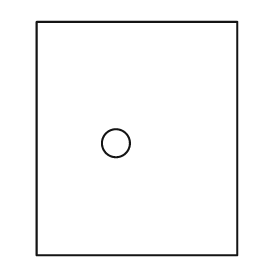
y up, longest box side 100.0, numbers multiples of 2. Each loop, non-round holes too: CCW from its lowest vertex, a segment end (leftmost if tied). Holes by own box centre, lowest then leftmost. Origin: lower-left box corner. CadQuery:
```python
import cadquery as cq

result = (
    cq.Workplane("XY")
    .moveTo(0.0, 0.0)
    .lineTo(86.0, 0.0)
    .lineTo(86.0, 100.0)
    .lineTo(0.0, 100.0)
    .close()
    .moveTo(34.0, 48.0)
    .circle(6.0)
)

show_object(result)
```